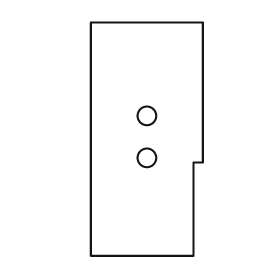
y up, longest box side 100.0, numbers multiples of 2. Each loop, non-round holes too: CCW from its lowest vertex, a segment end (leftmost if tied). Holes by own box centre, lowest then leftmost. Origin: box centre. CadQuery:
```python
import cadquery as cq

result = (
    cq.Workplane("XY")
    .moveTo(-24.0, -50.0)
    .lineTo(20.0, -50.0)
    .lineTo(20.0, -10.0)
    .lineTo(24.0, -10.0)
    .lineTo(24.0, 50.0)
    .lineTo(-24.0, 50.0)
    .close()
    .moveTo(0.0, -8.0)
    .circle(4.0)
    .moveTo(0.0, 10.0)
    .circle(4.0)
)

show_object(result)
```